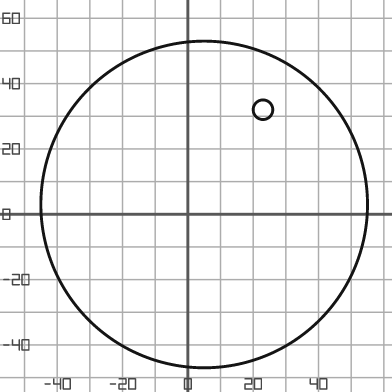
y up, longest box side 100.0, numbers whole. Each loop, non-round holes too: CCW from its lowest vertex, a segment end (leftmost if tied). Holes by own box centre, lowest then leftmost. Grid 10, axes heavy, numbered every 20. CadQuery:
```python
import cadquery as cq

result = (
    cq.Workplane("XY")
    .moveTo(5.0, 3.0)
    .circle(50.0)
    .moveTo(23.0, 32.0)
    .circle(3.0)
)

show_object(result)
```